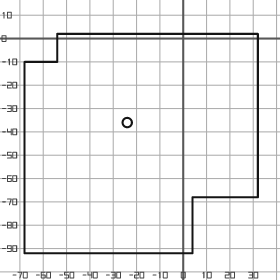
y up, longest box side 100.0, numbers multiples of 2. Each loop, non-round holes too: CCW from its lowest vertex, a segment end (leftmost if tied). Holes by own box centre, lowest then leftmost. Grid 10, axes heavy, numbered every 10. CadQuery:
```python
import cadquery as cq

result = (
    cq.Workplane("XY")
    .moveTo(-68.0, -92.0)
    .lineTo(4.0, -92.0)
    .lineTo(4.0, -68.0)
    .lineTo(32.0, -68.0)
    .lineTo(32.0, 2.0)
    .lineTo(-54.0, 2.0)
    .lineTo(-54.0, -10.0)
    .lineTo(-68.0, -10.0)
    .close()
    .moveTo(-24.0, -36.0)
    .circle(2.0)
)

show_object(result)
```